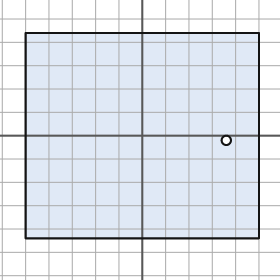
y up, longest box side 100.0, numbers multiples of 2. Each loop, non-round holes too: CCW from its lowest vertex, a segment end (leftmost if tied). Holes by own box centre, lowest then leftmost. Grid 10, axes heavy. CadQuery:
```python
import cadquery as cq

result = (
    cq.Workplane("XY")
    .moveTo(-50.0, -44.0)
    .lineTo(50.0, -44.0)
    .lineTo(50.0, 44.0)
    .lineTo(-50.0, 44.0)
    .close()
    .moveTo(36.0, -2.0)
    .circle(2.0)
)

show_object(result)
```